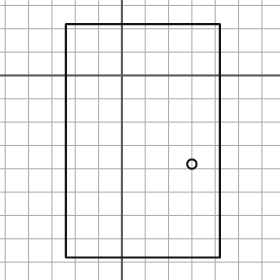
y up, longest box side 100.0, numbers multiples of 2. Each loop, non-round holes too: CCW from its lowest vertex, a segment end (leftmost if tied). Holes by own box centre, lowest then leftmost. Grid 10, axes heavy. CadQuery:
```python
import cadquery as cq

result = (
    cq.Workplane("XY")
    .moveTo(-24.0, -78.0)
    .lineTo(42.0, -78.0)
    .lineTo(42.0, 22.0)
    .lineTo(-24.0, 22.0)
    .close()
    .moveTo(30.0, -38.0)
    .circle(2.0)
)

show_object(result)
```